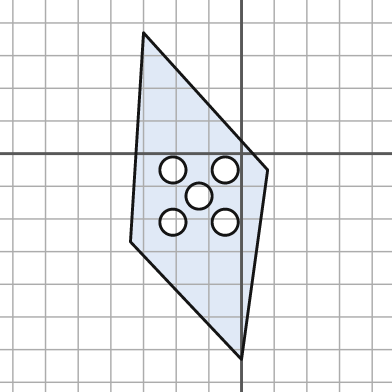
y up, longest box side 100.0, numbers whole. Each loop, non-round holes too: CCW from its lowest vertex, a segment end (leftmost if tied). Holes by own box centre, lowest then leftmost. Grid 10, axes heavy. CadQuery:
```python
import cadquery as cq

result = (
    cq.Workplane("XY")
    .moveTo(0.0, -63.0)
    .lineTo(8.0, -5.0)
    .lineTo(-30.0, 37.0)
    .lineTo(-34.0, -27.0)
    .close()
    .moveTo(-21.0, -21.0)
    .circle(4.0)
    .moveTo(-5.0, -21.0)
    .circle(4.0)
    .moveTo(-13.0, -13.0)
    .circle(4.0)
    .moveTo(-21.0, -5.0)
    .circle(4.0)
    .moveTo(-5.0, -5.0)
    .circle(4.0)
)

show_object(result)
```